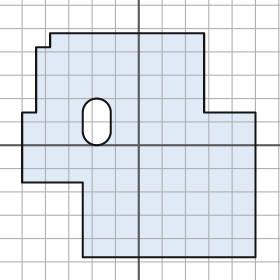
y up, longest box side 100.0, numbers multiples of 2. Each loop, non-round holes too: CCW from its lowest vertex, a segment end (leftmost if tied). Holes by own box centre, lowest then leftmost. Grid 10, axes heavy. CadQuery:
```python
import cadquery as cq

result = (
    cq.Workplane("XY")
    .moveTo(-24.0, -48.0)
    .lineTo(50.0, -48.0)
    .lineTo(50.0, 14.0)
    .lineTo(28.0, 14.0)
    .lineTo(28.0, 48.0)
    .lineTo(-38.0, 48.0)
    .lineTo(-38.0, 42.0)
    .lineTo(-44.0, 42.0)
    .lineTo(-44.0, 14.0)
    .lineTo(-50.0, 14.0)
    .lineTo(-50.0, -16.0)
    .lineTo(-24.0, -16.0)
    .close()
    .moveTo(-24.0, 6.0)
    .threePointArc((-18.0, 0.0), (-12.0, 6.0))
    .lineTo(-12.0, 14.0)
    .threePointArc((-18.0, 20.0), (-24.0, 14.0))
    .close()
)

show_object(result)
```